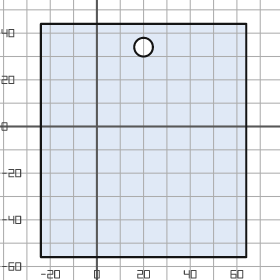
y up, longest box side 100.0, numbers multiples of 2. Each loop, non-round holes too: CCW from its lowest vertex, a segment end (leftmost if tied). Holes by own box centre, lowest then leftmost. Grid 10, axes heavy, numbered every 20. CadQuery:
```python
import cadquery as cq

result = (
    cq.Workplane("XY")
    .moveTo(-24.0, -56.0)
    .lineTo(64.0, -56.0)
    .lineTo(64.0, 44.0)
    .lineTo(-24.0, 44.0)
    .close()
    .moveTo(20.0, 34.0)
    .circle(4.0)
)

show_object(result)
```